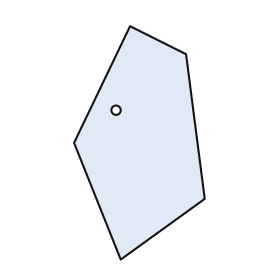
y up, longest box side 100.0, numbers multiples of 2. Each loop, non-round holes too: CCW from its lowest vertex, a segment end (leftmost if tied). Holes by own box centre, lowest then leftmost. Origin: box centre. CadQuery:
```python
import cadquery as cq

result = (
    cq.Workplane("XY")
    .moveTo(-8.0, -50.0)
    .lineTo(28.0, -24.0)
    .lineTo(20.0, 38.0)
    .lineTo(-4.0, 50.0)
    .lineTo(-28.0, 0.0)
    .close()
    .moveTo(-10.0, 14.0)
    .circle(2.0)
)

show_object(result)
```